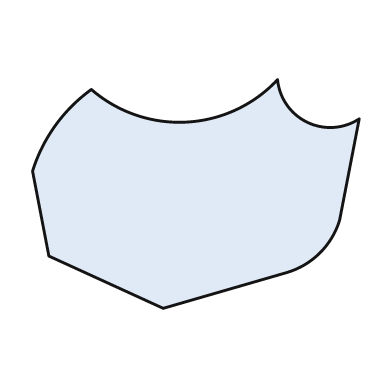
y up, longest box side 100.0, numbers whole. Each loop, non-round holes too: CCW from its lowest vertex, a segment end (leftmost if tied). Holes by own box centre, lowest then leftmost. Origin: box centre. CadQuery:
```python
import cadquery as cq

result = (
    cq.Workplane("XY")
    .moveTo(-10.0, -35.0)
    .lineTo(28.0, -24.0)
    .threePointArc((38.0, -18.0), (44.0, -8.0))
    .lineTo(50.0, 23.0)
    .threePointArc((34.0, 22.0), (25.0, 35.0))
    .threePointArc((-3.0, 22.0), (-32.0, 32.0))
    .threePointArc((-43.0, 21.0), (-50.0, 7.0))
    .lineTo(-45.0, -19.0)
    .close()
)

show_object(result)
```